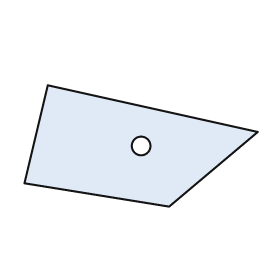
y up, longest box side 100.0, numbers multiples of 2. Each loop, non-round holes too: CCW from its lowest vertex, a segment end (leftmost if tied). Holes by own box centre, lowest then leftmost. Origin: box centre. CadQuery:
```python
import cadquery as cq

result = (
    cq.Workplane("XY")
    .moveTo(12.0, -26.0)
    .lineTo(50.0, 6.0)
    .lineTo(-40.0, 26.0)
    .lineTo(-50.0, -16.0)
    .close()
    .moveTo(0.0, 0.0)
    .circle(4.0)
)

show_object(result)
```